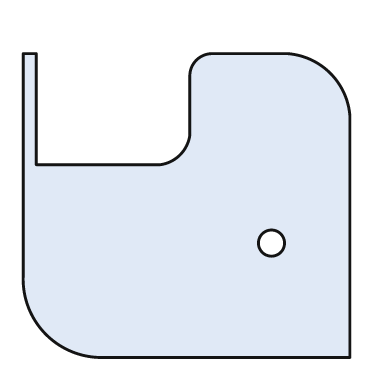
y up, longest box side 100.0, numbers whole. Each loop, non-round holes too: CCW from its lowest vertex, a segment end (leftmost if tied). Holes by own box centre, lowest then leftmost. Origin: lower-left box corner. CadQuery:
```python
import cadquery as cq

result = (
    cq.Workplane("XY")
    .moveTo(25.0, 0.0)
    .lineTo(100.0, 0.0)
    .lineTo(100.0, 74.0)
    .threePointArc((94.0, 87.0), (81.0, 93.0))
    .lineTo(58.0, 93.0)
    .threePointArc((53.0, 91.0), (51.0, 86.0))
    .lineTo(51.0, 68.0)
    .threePointArc((48.0, 62.0), (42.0, 59.0))
    .lineTo(4.0, 59.0)
    .lineTo(4.0, 93.0)
    .lineTo(0.0, 93.0)
    .lineTo(0.0, 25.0)
    .threePointArc((7.0, 7.0), (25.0, 0.0))
    .close()
    .moveTo(76.0, 35.0)
    .circle(4.0)
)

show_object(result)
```